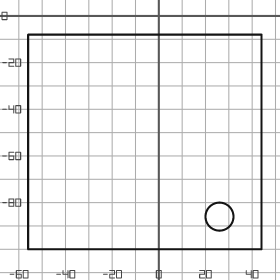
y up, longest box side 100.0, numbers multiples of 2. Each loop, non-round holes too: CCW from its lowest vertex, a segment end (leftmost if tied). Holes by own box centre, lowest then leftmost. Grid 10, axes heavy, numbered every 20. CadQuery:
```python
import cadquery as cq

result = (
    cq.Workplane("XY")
    .moveTo(-56.0, -100.0)
    .lineTo(44.0, -100.0)
    .lineTo(44.0, -8.0)
    .lineTo(-56.0, -8.0)
    .close()
    .moveTo(26.0, -86.0)
    .circle(6.0)
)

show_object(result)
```